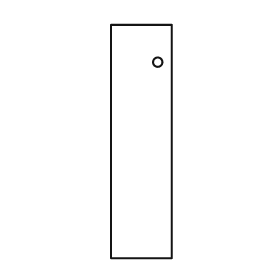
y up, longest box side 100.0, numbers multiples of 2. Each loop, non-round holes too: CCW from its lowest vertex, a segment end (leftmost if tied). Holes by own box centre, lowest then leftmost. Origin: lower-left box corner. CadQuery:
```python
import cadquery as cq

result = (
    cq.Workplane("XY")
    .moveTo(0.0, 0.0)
    .lineTo(26.0, 0.0)
    .lineTo(26.0, 100.0)
    .lineTo(0.0, 100.0)
    .close()
    .moveTo(20.0, 84.0)
    .circle(2.0)
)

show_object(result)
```